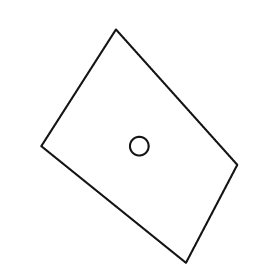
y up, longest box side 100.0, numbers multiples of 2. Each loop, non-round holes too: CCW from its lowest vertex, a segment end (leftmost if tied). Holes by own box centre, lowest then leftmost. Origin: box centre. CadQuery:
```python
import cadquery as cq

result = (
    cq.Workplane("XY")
    .moveTo(20.0, -50.0)
    .lineTo(42.0, -8.0)
    .lineTo(-10.0, 50.0)
    .lineTo(-42.0, 0.0)
    .close()
    .moveTo(0.0, 0.0)
    .circle(4.0)
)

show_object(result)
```